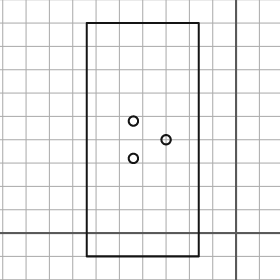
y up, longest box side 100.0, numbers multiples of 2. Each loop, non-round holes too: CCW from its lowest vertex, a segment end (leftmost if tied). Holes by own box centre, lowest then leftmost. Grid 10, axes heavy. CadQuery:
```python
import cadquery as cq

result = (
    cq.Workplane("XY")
    .moveTo(-64.0, -10.0)
    .lineTo(-16.0, -10.0)
    .lineTo(-16.0, 90.0)
    .lineTo(-64.0, 90.0)
    .close()
    .moveTo(-44.0, 32.0)
    .circle(2.0)
    .moveTo(-30.0, 40.0)
    .circle(2.0)
    .moveTo(-44.0, 48.0)
    .circle(2.0)
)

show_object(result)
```